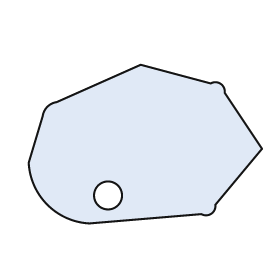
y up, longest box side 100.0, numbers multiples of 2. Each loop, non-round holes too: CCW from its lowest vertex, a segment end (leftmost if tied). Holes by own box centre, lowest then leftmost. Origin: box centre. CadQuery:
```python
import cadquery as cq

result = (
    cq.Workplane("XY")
    .moveTo(-24.0, -34.0)
    .lineTo(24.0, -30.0)
    .threePointArc((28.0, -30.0), (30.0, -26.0))
    .lineTo(50.0, -2.0)
    .lineTo(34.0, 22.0)
    .threePointArc((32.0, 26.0), (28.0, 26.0))
    .lineTo(-2.0, 34.0)
    .lineTo(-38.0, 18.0)
    .threePointArc((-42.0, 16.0), (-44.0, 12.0))
    .lineTo(-50.0, -8.0)
    .threePointArc((-42.0, -26.0), (-24.0, -34.0))
    .close()
    .moveTo(-16.0, -22.0)
    .circle(6.0)
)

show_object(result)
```